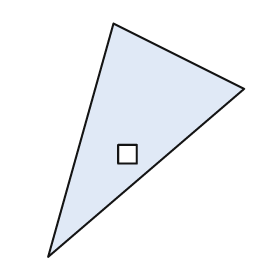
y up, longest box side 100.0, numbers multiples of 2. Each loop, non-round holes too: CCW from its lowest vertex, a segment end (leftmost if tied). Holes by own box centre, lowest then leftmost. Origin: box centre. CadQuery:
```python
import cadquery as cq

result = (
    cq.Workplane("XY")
    .moveTo(-42.0, -50.0)
    .lineTo(42.0, 22.0)
    .lineTo(-14.0, 50.0)
    .close()
    .moveTo(-12.0, -10.0)
    .lineTo(-4.0, -10.0)
    .lineTo(-4.0, -2.0)
    .lineTo(-12.0, -2.0)
    .close()
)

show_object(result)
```